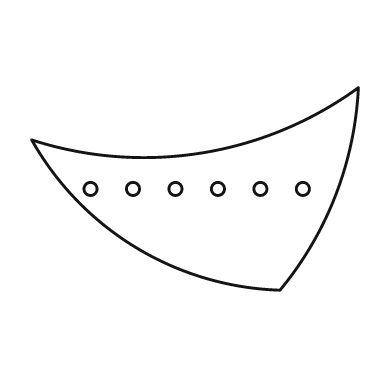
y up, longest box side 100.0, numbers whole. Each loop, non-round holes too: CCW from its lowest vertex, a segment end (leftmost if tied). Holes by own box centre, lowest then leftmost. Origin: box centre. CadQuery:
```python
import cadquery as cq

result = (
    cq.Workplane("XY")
    .moveTo(26.0, -31.0)
    .threePointArc((43.0, -2.0), (50.0, 31.0))
    .threePointArc((2.0, 11.0), (-50.0, 15.0))
    .threePointArc((-18.0, -18.0), (26.0, -31.0))
    .close()
    .moveTo(-32.0, 0.0)
    .circle(2.0)
    .moveTo(-19.0, 0.0)
    .circle(2.0)
    .moveTo(-6.0, 0.0)
    .circle(2.0)
    .moveTo(7.0, 0.0)
    .circle(2.0)
    .moveTo(20.0, 0.0)
    .circle(2.0)
    .moveTo(33.0, 0.0)
    .circle(2.0)
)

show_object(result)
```